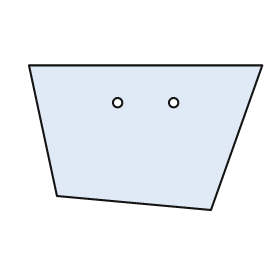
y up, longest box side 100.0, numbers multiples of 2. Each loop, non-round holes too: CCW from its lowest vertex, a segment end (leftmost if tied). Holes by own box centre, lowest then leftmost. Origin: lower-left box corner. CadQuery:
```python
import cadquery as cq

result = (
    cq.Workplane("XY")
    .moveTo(78.0, 0.0)
    .lineTo(100.0, 62.0)
    .lineTo(0.0, 62.0)
    .lineTo(12.0, 6.0)
    .close()
    .moveTo(38.0, 46.0)
    .circle(2.0)
    .moveTo(62.0, 46.0)
    .circle(2.0)
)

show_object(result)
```